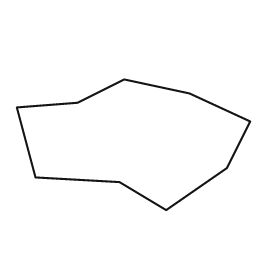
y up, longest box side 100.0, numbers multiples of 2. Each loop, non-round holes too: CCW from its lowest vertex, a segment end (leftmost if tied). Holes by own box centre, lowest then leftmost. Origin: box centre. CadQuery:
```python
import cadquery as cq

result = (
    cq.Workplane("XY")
    .moveTo(14.0, -28.0)
    .lineTo(40.0, -10.0)
    .lineTo(50.0, 10.0)
    .lineTo(24.0, 22.0)
    .lineTo(-4.0, 28.0)
    .lineTo(-24.0, 18.0)
    .lineTo(-50.0, 16.0)
    .lineTo(-42.0, -14.0)
    .lineTo(-6.0, -16.0)
    .close()
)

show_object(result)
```